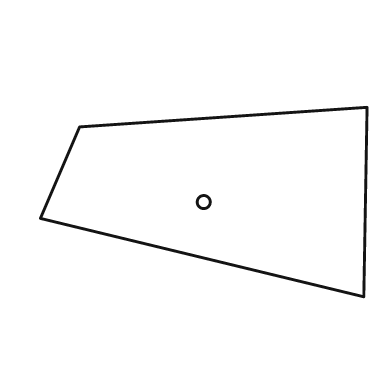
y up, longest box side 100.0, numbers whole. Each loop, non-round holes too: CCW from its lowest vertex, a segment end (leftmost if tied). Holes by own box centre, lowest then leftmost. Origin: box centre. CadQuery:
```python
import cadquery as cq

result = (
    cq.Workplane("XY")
    .moveTo(49.0, -29.0)
    .lineTo(50.0, 29.0)
    .lineTo(-38.0, 23.0)
    .lineTo(-50.0, -5.0)
    .close()
    .moveTo(0.0, 0.0)
    .circle(2.0)
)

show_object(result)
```